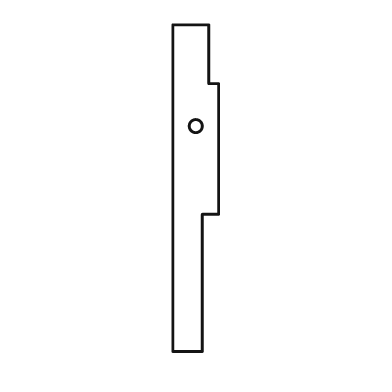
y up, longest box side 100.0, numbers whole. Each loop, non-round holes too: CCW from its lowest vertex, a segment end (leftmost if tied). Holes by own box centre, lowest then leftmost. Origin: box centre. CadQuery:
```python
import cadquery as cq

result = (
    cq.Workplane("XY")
    .moveTo(-7.0, -50.0)
    .lineTo(2.0, -50.0)
    .lineTo(2.0, -8.0)
    .lineTo(7.0, -8.0)
    .lineTo(7.0, 32.0)
    .lineTo(4.0, 32.0)
    .lineTo(4.0, 50.0)
    .lineTo(-7.0, 50.0)
    .close()
    .moveTo(0.0, 19.0)
    .circle(2.0)
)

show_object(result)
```